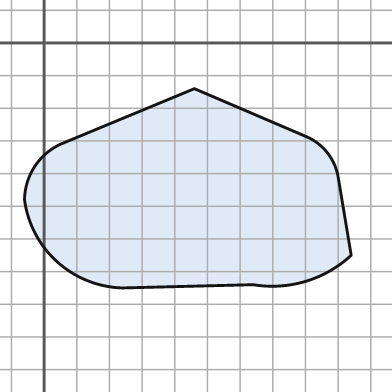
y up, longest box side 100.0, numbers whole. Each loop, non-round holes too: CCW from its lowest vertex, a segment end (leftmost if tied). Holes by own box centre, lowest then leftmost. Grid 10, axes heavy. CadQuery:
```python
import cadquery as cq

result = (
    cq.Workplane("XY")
    .moveTo(24.0, -75.0)
    .lineTo(64.0, -74.0)
    .threePointArc((80.0, -73.0), (94.0, -65.0))
    .lineTo(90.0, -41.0)
    .threePointArc((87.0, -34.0), (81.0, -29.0))
    .lineTo(46.0, -14.0)
    .lineTo(5.0, -31.0)
    .threePointArc((-3.0, -38.0), (-6.0, -48.0))
    .threePointArc((4.0, -67.0), (24.0, -75.0))
    .close()
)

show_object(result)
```